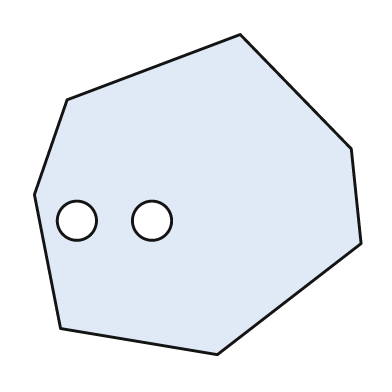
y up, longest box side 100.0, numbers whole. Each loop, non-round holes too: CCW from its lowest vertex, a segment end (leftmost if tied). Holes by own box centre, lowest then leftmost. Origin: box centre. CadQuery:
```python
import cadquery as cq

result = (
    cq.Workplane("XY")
    .moveTo(6.0, -49.0)
    .lineTo(50.0, -15.0)
    .lineTo(47.0, 14.0)
    .lineTo(13.0, 49.0)
    .lineTo(-40.0, 29.0)
    .lineTo(-50.0, 0.0)
    .lineTo(-42.0, -41.0)
    .close()
    .moveTo(-37.0, -8.0)
    .circle(6.0)
    .moveTo(-14.0, -8.0)
    .circle(6.0)
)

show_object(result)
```